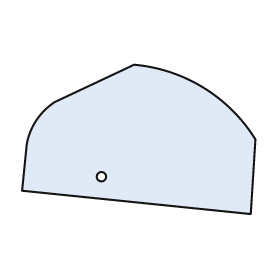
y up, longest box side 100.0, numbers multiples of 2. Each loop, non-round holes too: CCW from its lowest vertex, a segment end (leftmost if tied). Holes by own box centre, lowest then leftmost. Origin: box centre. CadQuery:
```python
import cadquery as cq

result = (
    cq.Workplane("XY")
    .moveTo(48.0, -32.0)
    .lineTo(50.0, 0.0)
    .threePointArc((28.0, 22.0), (-2.0, 32.0))
    .lineTo(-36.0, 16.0)
    .threePointArc((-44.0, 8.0), (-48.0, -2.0))
    .lineTo(-50.0, -22.0)
    .close()
    .moveTo(-16.0, -16.0)
    .circle(2.0)
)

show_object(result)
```